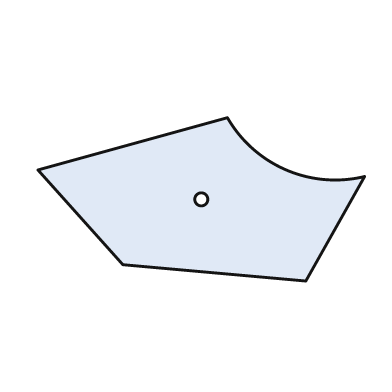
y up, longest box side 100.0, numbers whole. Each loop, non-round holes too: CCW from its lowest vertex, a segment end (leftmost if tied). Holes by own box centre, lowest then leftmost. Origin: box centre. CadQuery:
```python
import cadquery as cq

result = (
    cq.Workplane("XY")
    .moveTo(32.0, -25.0)
    .lineTo(50.0, 7.0)
    .threePointArc((26.0, 9.0), (8.0, 25.0))
    .lineTo(-50.0, 9.0)
    .lineTo(-24.0, -20.0)
    .close()
    .moveTo(0.0, 0.0)
    .circle(2.0)
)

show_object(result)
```